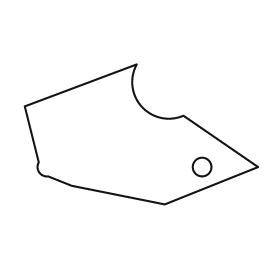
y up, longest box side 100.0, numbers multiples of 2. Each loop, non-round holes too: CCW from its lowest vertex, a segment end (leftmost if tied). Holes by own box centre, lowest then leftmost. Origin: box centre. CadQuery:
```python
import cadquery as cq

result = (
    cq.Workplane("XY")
    .moveTo(10.0, -30.0)
    .lineTo(50.0, -14.0)
    .lineTo(18.0, 8.0)
    .threePointArc((0.0, 12.0), (-2.0, 30.0))
    .lineTo(-50.0, 12.0)
    .lineTo(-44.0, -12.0)
    .threePointArc((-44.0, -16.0), (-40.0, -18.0))
    .lineTo(-30.0, -22.0)
    .close()
    .moveTo(26.0, -14.0)
    .circle(4.0)
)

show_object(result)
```